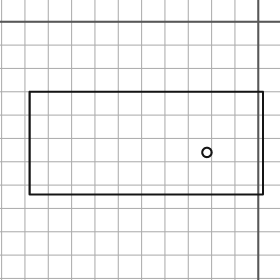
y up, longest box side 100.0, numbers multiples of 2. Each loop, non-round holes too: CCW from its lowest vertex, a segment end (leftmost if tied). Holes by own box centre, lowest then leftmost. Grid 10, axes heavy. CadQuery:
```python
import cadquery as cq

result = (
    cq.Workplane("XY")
    .moveTo(-98.0, -74.0)
    .lineTo(2.0, -74.0)
    .lineTo(2.0, -30.0)
    .lineTo(-98.0, -30.0)
    .close()
    .moveTo(-22.0, -56.0)
    .circle(2.0)
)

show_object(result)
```